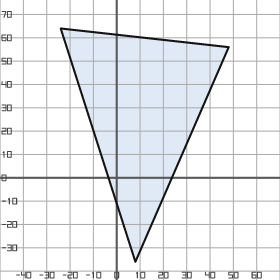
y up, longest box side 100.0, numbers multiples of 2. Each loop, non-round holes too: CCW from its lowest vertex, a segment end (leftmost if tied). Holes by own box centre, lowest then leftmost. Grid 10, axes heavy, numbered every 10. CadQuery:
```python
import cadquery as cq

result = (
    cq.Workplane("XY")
    .moveTo(8.0, -36.0)
    .lineTo(48.0, 56.0)
    .lineTo(-24.0, 64.0)
    .close()
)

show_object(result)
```